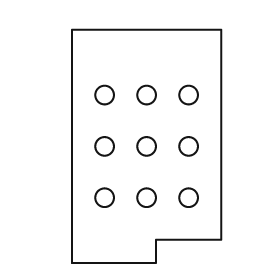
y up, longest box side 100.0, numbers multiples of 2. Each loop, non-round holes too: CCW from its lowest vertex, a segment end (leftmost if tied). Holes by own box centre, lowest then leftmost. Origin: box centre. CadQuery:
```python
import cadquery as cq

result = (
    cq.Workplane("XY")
    .moveTo(-32.0, -50.0)
    .lineTo(4.0, -50.0)
    .lineTo(4.0, -40.0)
    .lineTo(32.0, -40.0)
    .lineTo(32.0, 50.0)
    .lineTo(-32.0, 50.0)
    .close()
    .moveTo(-18.0, -22.0)
    .circle(4.0)
    .moveTo(0.0, -22.0)
    .circle(4.0)
    .moveTo(18.0, -22.0)
    .circle(4.0)
    .moveTo(-18.0, 0.0)
    .circle(4.0)
    .moveTo(0.0, 0.0)
    .circle(4.0)
    .moveTo(18.0, 0.0)
    .circle(4.0)
    .moveTo(-18.0, 22.0)
    .circle(4.0)
    .moveTo(0.0, 22.0)
    .circle(4.0)
    .moveTo(18.0, 22.0)
    .circle(4.0)
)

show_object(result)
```